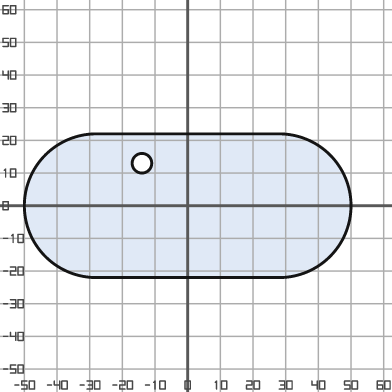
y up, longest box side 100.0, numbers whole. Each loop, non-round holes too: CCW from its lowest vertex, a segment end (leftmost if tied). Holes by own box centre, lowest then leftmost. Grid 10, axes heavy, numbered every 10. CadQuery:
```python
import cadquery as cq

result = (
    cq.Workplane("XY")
    .moveTo(-28.0, -22.0)
    .lineTo(28.0, -22.0)
    .threePointArc((50.0, 0.0), (28.0, 22.0))
    .lineTo(-28.0, 22.0)
    .threePointArc((-50.0, 0.0), (-28.0, -22.0))
    .close()
    .moveTo(-14.0, 13.0)
    .circle(3.0)
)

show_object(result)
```